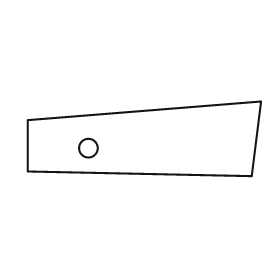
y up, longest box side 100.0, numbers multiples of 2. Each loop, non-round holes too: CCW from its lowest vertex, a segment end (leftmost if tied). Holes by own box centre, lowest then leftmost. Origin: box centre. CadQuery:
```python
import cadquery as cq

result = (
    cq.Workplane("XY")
    .moveTo(46.0, -16.0)
    .lineTo(50.0, 16.0)
    .lineTo(-50.0, 8.0)
    .lineTo(-50.0, -14.0)
    .close()
    .moveTo(-24.0, -4.0)
    .circle(4.0)
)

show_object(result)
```